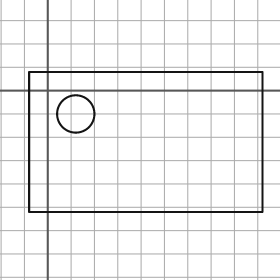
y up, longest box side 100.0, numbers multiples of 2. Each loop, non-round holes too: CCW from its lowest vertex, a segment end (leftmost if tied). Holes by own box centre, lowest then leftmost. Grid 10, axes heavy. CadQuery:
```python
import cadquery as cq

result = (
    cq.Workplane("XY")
    .moveTo(-8.0, -52.0)
    .lineTo(92.0, -52.0)
    .lineTo(92.0, 8.0)
    .lineTo(-8.0, 8.0)
    .close()
    .moveTo(12.0, -10.0)
    .circle(8.0)
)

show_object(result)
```